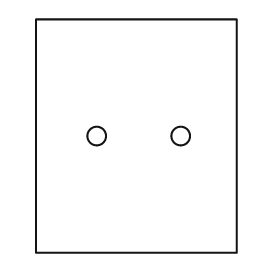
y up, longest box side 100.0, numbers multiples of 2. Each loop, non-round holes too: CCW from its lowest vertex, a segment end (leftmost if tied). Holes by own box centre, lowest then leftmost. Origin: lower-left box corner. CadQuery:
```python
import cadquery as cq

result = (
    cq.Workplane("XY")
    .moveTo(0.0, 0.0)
    .lineTo(86.0, 0.0)
    .lineTo(86.0, 100.0)
    .lineTo(0.0, 100.0)
    .close()
    .moveTo(26.0, 50.0)
    .circle(4.0)
    .moveTo(62.0, 50.0)
    .circle(4.0)
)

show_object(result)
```